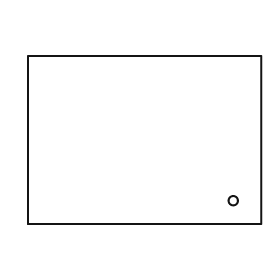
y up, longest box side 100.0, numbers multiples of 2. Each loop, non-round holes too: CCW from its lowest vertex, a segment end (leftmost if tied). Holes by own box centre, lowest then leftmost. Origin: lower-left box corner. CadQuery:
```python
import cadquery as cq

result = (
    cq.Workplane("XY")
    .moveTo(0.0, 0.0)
    .lineTo(100.0, 0.0)
    .lineTo(100.0, 72.0)
    .lineTo(0.0, 72.0)
    .close()
    .moveTo(88.0, 10.0)
    .circle(2.0)
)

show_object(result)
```